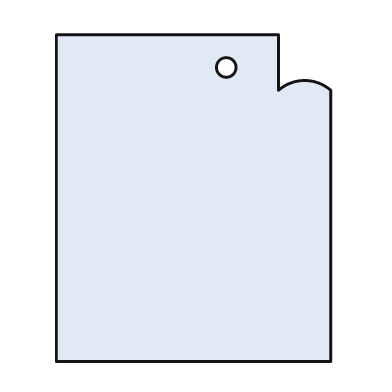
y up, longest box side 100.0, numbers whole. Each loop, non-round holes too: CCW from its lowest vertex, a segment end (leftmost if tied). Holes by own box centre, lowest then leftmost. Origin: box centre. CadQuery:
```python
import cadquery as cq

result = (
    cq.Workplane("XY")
    .moveTo(-42.0, -50.0)
    .lineTo(42.0, -50.0)
    .lineTo(42.0, 33.0)
    .threePointArc((34.0, 36.0), (26.0, 33.0))
    .lineTo(26.0, 50.0)
    .lineTo(-42.0, 50.0)
    .close()
    .moveTo(10.0, 40.0)
    .circle(3.0)
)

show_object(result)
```